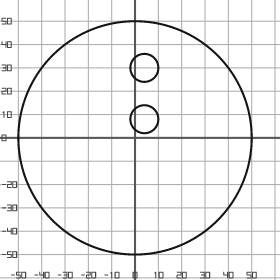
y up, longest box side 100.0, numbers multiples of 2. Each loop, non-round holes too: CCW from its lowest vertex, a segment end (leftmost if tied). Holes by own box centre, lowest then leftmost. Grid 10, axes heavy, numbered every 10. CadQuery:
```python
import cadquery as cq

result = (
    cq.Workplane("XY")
    .moveTo(0.0, 0.0)
    .circle(50.0)
    .moveTo(4.0, 8.0)
    .circle(6.0)
    .moveTo(4.0, 30.0)
    .circle(6.0)
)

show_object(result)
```